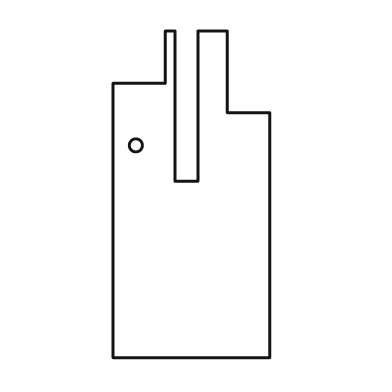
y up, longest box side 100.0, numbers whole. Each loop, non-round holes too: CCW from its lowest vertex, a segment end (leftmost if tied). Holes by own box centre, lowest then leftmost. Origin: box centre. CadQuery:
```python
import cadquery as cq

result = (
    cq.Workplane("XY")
    .moveTo(-24.0, -50.0)
    .lineTo(24.0, -50.0)
    .lineTo(24.0, 25.0)
    .lineTo(11.0, 25.0)
    .lineTo(11.0, 50.0)
    .lineTo(2.0, 50.0)
    .lineTo(2.0, 4.0)
    .lineTo(-5.0, 4.0)
    .lineTo(-5.0, 50.0)
    .lineTo(-8.0, 50.0)
    .lineTo(-8.0, 34.0)
    .lineTo(-24.0, 34.0)
    .close()
    .moveTo(-17.0, 15.0)
    .circle(2.0)
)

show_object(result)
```